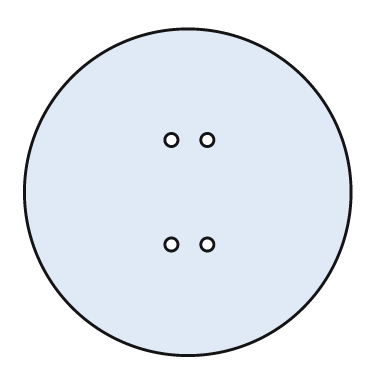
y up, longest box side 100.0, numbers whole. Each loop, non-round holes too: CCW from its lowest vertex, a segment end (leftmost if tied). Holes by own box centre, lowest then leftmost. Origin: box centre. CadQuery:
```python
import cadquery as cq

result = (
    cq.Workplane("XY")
    .moveTo(0.0, 0.0)
    .circle(50.0)
    .moveTo(-5.0, -16.0)
    .circle(2.0)
    .moveTo(6.0, -16.0)
    .circle(2.0)
    .moveTo(-5.0, 16.0)
    .circle(2.0)
    .moveTo(6.0, 16.0)
    .circle(2.0)
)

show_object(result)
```